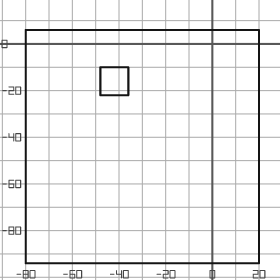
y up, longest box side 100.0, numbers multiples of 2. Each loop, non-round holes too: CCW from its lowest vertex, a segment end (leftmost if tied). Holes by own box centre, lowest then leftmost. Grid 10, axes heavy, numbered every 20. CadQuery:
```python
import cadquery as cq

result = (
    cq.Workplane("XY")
    .moveTo(-80.0, -94.0)
    .lineTo(20.0, -94.0)
    .lineTo(20.0, 6.0)
    .lineTo(-80.0, 6.0)
    .close()
    .moveTo(-48.0, -22.0)
    .lineTo(-36.0, -22.0)
    .lineTo(-36.0, -10.0)
    .lineTo(-48.0, -10.0)
    .close()
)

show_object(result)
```